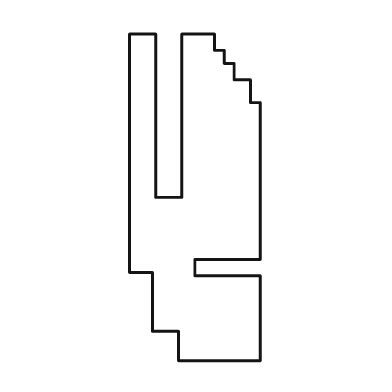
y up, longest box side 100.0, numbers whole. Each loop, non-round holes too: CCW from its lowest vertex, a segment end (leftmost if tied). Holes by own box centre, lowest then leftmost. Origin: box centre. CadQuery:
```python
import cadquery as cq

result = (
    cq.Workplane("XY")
    .moveTo(-5.0, -50.0)
    .lineTo(20.0, -50.0)
    .lineTo(20.0, -24.0)
    .lineTo(0.0, -24.0)
    .lineTo(0.0, -19.0)
    .lineTo(20.0, -19.0)
    .lineTo(20.0, 29.0)
    .lineTo(17.0, 29.0)
    .lineTo(17.0, 36.0)
    .lineTo(12.0, 36.0)
    .lineTo(12.0, 41.0)
    .lineTo(9.0, 41.0)
    .lineTo(9.0, 45.0)
    .lineTo(6.0, 45.0)
    .lineTo(6.0, 50.0)
    .lineTo(-4.0, 50.0)
    .lineTo(-4.0, 0.0)
    .lineTo(-12.0, 0.0)
    .lineTo(-12.0, 50.0)
    .lineTo(-20.0, 50.0)
    .lineTo(-20.0, -23.0)
    .lineTo(-13.0, -23.0)
    .lineTo(-13.0, -41.0)
    .lineTo(-5.0, -41.0)
    .close()
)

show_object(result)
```